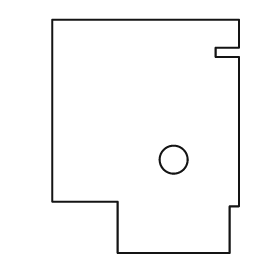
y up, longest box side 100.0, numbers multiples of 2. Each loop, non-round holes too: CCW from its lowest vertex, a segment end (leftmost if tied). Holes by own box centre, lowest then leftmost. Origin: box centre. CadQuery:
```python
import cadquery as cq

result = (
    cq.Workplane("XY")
    .moveTo(-12.0, -50.0)
    .lineTo(36.0, -50.0)
    .lineTo(36.0, -30.0)
    .lineTo(40.0, -30.0)
    .lineTo(40.0, 34.0)
    .lineTo(30.0, 34.0)
    .lineTo(30.0, 38.0)
    .lineTo(40.0, 38.0)
    .lineTo(40.0, 50.0)
    .lineTo(-40.0, 50.0)
    .lineTo(-40.0, -28.0)
    .lineTo(-12.0, -28.0)
    .close()
    .moveTo(12.0, -10.0)
    .circle(6.0)
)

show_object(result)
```